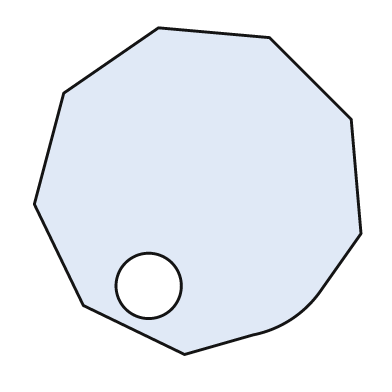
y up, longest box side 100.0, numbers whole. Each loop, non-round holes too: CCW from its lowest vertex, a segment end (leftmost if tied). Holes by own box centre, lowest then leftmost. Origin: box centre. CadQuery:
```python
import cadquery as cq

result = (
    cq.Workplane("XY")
    .moveTo(-4.0, -50.0)
    .lineTo(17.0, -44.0)
    .threePointArc((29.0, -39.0), (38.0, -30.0))
    .lineTo(50.0, -13.0)
    .lineTo(47.0, 22.0)
    .lineTo(22.0, 47.0)
    .lineTo(-12.0, 50.0)
    .lineTo(-41.0, 30.0)
    .lineTo(-50.0, -4.0)
    .lineTo(-35.0, -35.0)
    .close()
    .moveTo(-15.0, -29.0)
    .circle(10.0)
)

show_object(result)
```